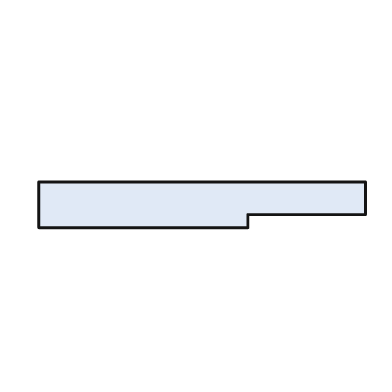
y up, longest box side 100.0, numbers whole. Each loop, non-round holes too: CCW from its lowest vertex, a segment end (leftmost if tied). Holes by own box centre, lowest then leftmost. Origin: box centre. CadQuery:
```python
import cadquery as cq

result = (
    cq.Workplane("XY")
    .moveTo(-50.0, -7.0)
    .lineTo(14.0, -7.0)
    .lineTo(14.0, -3.0)
    .lineTo(50.0, -3.0)
    .lineTo(50.0, 7.0)
    .lineTo(-50.0, 7.0)
    .close()
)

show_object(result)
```